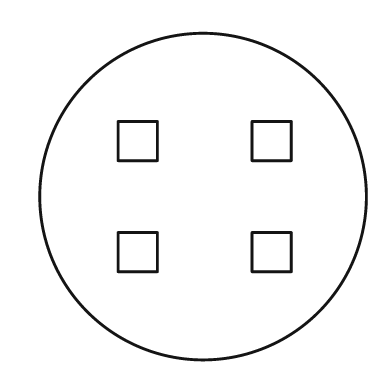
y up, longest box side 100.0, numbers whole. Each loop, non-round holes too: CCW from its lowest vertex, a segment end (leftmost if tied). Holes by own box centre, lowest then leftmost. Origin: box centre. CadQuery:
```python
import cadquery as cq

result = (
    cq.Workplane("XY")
    .moveTo(0.0, 0.0)
    .circle(50.0)
    .moveTo(-26.0, -23.0)
    .lineTo(-14.0, -23.0)
    .lineTo(-14.0, -11.0)
    .lineTo(-26.0, -11.0)
    .close()
    .moveTo(15.0, -23.0)
    .lineTo(27.0, -23.0)
    .lineTo(27.0, -11.0)
    .lineTo(15.0, -11.0)
    .close()
    .moveTo(-26.0, 11.0)
    .lineTo(-14.0, 11.0)
    .lineTo(-14.0, 23.0)
    .lineTo(-26.0, 23.0)
    .close()
    .moveTo(15.0, 11.0)
    .lineTo(27.0, 11.0)
    .lineTo(27.0, 23.0)
    .lineTo(15.0, 23.0)
    .close()
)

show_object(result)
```